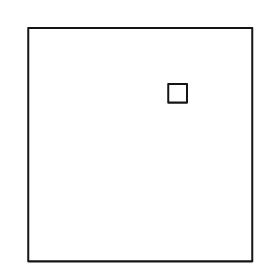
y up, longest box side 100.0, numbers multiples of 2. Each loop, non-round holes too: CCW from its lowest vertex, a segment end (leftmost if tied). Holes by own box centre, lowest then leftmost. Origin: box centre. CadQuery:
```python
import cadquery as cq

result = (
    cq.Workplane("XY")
    .moveTo(-48.0, -50.0)
    .lineTo(48.0, -50.0)
    .lineTo(48.0, 50.0)
    .lineTo(-48.0, 50.0)
    .close()
    .moveTo(12.0, 18.0)
    .lineTo(20.0, 18.0)
    .lineTo(20.0, 26.0)
    .lineTo(12.0, 26.0)
    .close()
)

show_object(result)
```